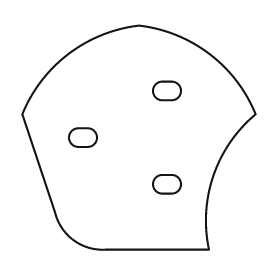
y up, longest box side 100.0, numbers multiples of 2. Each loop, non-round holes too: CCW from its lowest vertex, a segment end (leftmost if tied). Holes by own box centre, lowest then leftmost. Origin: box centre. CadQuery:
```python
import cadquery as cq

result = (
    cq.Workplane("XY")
    .moveTo(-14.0, -48.0)
    .lineTo(30.0, -48.0)
    .threePointArc((32.0, -16.0), (50.0, 10.0))
    .threePointArc((30.0, 36.0), (0.0, 48.0))
    .threePointArc((-30.0, 36.0), (-50.0, 10.0))
    .lineTo(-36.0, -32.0)
    .threePointArc((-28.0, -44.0), (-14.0, -48.0))
    .close()
    .moveTo(10.0, -24.0)
    .lineTo(14.0, -24.0)
    .threePointArc((18.0, -20.0), (14.0, -16.0))
    .lineTo(10.0, -16.0)
    .threePointArc((6.0, -20.0), (10.0, -24.0))
    .close()
    .moveTo(-26.0, -4.0)
    .lineTo(-22.0, -4.0)
    .threePointArc((-18.0, 0.0), (-22.0, 4.0))
    .lineTo(-26.0, 4.0)
    .threePointArc((-30.0, 0.0), (-26.0, -4.0))
    .close()
    .moveTo(10.0, 16.0)
    .lineTo(14.0, 16.0)
    .threePointArc((18.0, 20.0), (14.0, 24.0))
    .lineTo(10.0, 24.0)
    .threePointArc((6.0, 20.0), (10.0, 16.0))
    .close()
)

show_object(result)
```